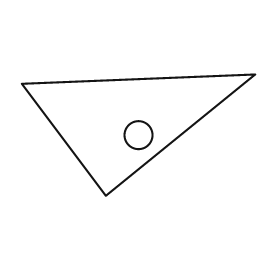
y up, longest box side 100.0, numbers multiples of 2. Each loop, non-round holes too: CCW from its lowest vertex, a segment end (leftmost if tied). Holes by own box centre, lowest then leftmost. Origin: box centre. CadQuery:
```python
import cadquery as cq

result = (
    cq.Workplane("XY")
    .moveTo(-14.0, -26.0)
    .lineTo(50.0, 26.0)
    .lineTo(-50.0, 22.0)
    .close()
    .moveTo(0.0, 0.0)
    .circle(6.0)
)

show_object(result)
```